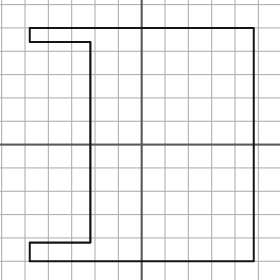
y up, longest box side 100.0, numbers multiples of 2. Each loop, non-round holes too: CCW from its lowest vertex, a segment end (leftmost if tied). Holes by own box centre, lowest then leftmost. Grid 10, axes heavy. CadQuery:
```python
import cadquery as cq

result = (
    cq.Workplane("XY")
    .moveTo(-48.0, -50.0)
    .lineTo(48.0, -50.0)
    .lineTo(48.0, 50.0)
    .lineTo(-48.0, 50.0)
    .lineTo(-48.0, 44.0)
    .lineTo(-22.0, 44.0)
    .lineTo(-22.0, -42.0)
    .lineTo(-48.0, -42.0)
    .close()
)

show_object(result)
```